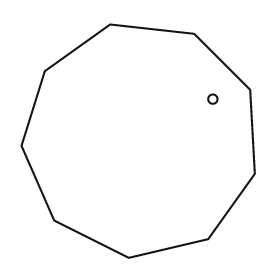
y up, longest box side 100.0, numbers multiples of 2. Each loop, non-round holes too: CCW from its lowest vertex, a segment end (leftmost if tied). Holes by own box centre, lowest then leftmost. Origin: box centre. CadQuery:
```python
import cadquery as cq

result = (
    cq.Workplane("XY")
    .moveTo(-4.0, -50.0)
    .lineTo(30.0, -42.0)
    .lineTo(50.0, -14.0)
    .lineTo(48.0, 22.0)
    .lineTo(24.0, 46.0)
    .lineTo(-12.0, 50.0)
    .lineTo(-40.0, 30.0)
    .lineTo(-50.0, -2.0)
    .lineTo(-36.0, -34.0)
    .close()
    .moveTo(32.0, 18.0)
    .circle(2.0)
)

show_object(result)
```